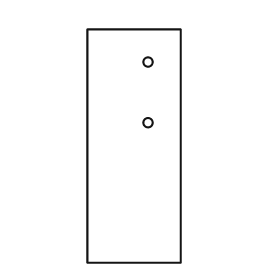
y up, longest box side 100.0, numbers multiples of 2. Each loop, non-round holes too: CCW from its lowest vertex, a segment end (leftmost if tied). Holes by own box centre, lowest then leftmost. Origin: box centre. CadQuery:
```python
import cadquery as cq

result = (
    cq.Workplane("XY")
    .moveTo(-20.0, -50.0)
    .lineTo(20.0, -50.0)
    .lineTo(20.0, 50.0)
    .lineTo(-20.0, 50.0)
    .close()
    .moveTo(6.0, 10.0)
    .circle(2.0)
    .moveTo(6.0, 36.0)
    .circle(2.0)
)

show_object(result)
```